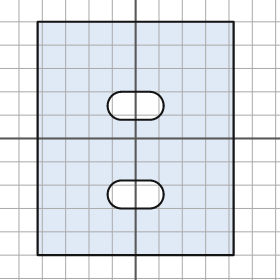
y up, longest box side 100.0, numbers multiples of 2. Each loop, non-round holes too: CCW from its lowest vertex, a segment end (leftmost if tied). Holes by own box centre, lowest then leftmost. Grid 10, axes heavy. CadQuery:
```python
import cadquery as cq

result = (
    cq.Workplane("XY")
    .moveTo(-42.0, -50.0)
    .lineTo(42.0, -50.0)
    .lineTo(42.0, 50.0)
    .lineTo(-42.0, 50.0)
    .close()
    .moveTo(-6.0, -30.0)
    .lineTo(6.0, -30.0)
    .threePointArc((12.0, -24.0), (6.0, -18.0))
    .lineTo(-6.0, -18.0)
    .threePointArc((-12.0, -24.0), (-6.0, -30.0))
    .close()
    .moveTo(-6.0, 8.0)
    .lineTo(6.0, 8.0)
    .threePointArc((12.0, 14.0), (6.0, 20.0))
    .lineTo(-6.0, 20.0)
    .threePointArc((-12.0, 14.0), (-6.0, 8.0))
    .close()
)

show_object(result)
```